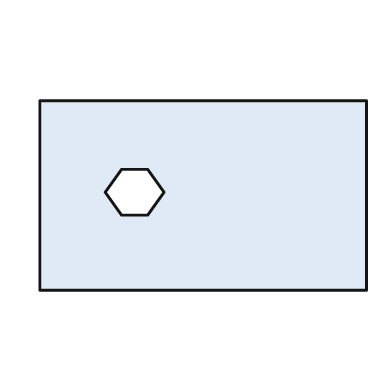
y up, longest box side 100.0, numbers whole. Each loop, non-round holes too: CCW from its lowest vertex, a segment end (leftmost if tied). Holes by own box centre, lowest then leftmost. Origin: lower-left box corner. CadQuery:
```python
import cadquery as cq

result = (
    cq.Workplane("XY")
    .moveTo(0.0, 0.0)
    .lineTo(100.0, 0.0)
    .lineTo(100.0, 58.0)
    .lineTo(0.0, 58.0)
    .close()
    .moveTo(25.0, 23.0)
    .lineTo(33.0, 23.0)
    .lineTo(38.0, 30.0)
    .lineTo(33.0, 37.0)
    .lineTo(25.0, 37.0)
    .lineTo(20.0, 30.0)
    .close()
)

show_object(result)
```